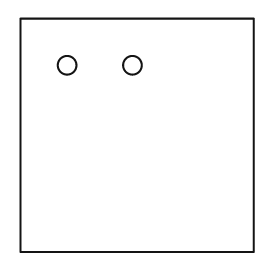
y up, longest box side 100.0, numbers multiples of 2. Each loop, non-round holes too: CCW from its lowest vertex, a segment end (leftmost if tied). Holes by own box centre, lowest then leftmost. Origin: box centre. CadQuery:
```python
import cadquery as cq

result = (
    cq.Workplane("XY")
    .moveTo(-50.0, -50.0)
    .lineTo(50.0, -50.0)
    .lineTo(50.0, 50.0)
    .lineTo(-50.0, 50.0)
    .close()
    .moveTo(-30.0, 30.0)
    .circle(4.0)
    .moveTo(-2.0, 30.0)
    .circle(4.0)
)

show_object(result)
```